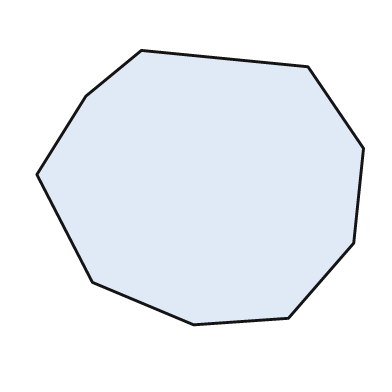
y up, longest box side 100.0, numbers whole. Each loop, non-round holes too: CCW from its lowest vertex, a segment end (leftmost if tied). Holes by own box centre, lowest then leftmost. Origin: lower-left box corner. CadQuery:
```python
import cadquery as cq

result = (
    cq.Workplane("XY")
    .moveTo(48.0, 0.0)
    .lineTo(77.0, 2.0)
    .lineTo(97.0, 25.0)
    .lineTo(100.0, 54.0)
    .lineTo(83.0, 79.0)
    .lineTo(32.0, 84.0)
    .lineTo(15.0, 70.0)
    .lineTo(0.0, 46.0)
    .lineTo(17.0, 13.0)
    .close()
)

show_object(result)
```